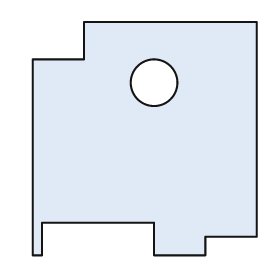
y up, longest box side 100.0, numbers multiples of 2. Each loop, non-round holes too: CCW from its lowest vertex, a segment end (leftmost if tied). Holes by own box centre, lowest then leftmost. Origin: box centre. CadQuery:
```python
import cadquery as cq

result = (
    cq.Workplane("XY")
    .moveTo(-48.0, -50.0)
    .lineTo(-44.0, -50.0)
    .lineTo(-44.0, -36.0)
    .lineTo(4.0, -36.0)
    .lineTo(4.0, -50.0)
    .lineTo(26.0, -50.0)
    .lineTo(26.0, -42.0)
    .lineTo(48.0, -42.0)
    .lineTo(48.0, 50.0)
    .lineTo(-26.0, 50.0)
    .lineTo(-26.0, 34.0)
    .lineTo(-48.0, 34.0)
    .close()
    .moveTo(4.0, 24.0)
    .circle(10.0)
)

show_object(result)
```